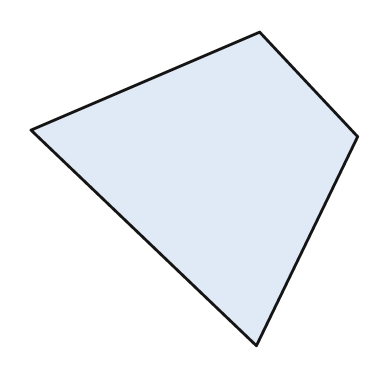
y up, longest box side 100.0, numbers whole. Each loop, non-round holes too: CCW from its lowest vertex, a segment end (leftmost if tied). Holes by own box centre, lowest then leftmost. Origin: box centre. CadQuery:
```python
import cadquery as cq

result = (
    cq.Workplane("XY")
    .moveTo(19.0, -48.0)
    .lineTo(50.0, 16.0)
    .lineTo(20.0, 48.0)
    .lineTo(-50.0, 18.0)
    .close()
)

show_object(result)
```